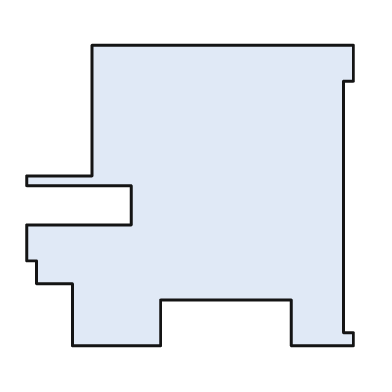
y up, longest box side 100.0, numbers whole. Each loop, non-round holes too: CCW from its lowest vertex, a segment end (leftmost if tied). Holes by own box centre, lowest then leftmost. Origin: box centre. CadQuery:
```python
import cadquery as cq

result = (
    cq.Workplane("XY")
    .moveTo(-36.0, -46.0)
    .lineTo(-9.0, -46.0)
    .lineTo(-9.0, -32.0)
    .lineTo(31.0, -32.0)
    .lineTo(31.0, -46.0)
    .lineTo(50.0, -46.0)
    .lineTo(50.0, -42.0)
    .lineTo(47.0, -42.0)
    .lineTo(47.0, 35.0)
    .lineTo(50.0, 35.0)
    .lineTo(50.0, 46.0)
    .lineTo(-30.0, 46.0)
    .lineTo(-30.0, 6.0)
    .lineTo(-50.0, 6.0)
    .lineTo(-50.0, 3.0)
    .lineTo(-18.0, 3.0)
    .lineTo(-18.0, -9.0)
    .lineTo(-50.0, -9.0)
    .lineTo(-50.0, -20.0)
    .lineTo(-47.0, -20.0)
    .lineTo(-47.0, -27.0)
    .lineTo(-36.0, -27.0)
    .close()
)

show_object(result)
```